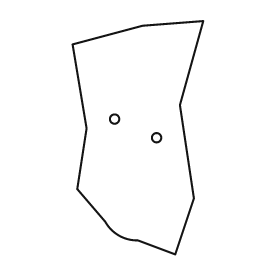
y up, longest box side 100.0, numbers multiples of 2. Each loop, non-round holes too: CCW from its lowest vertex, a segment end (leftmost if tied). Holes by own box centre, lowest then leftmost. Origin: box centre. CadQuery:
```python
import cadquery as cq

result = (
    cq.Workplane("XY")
    .moveTo(16.0, -50.0)
    .lineTo(24.0, -26.0)
    .lineTo(18.0, 14.0)
    .lineTo(28.0, 50.0)
    .lineTo(2.0, 48.0)
    .lineTo(-28.0, 40.0)
    .lineTo(-22.0, 4.0)
    .lineTo(-26.0, -22.0)
    .lineTo(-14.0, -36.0)
    .threePointArc((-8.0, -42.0), (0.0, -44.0))
    .close()
    .moveTo(8.0, 0.0)
    .circle(2.0)
    .moveTo(-10.0, 8.0)
    .circle(2.0)
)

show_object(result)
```